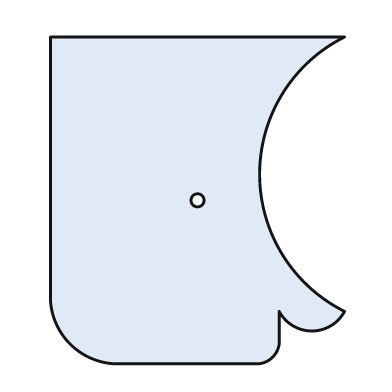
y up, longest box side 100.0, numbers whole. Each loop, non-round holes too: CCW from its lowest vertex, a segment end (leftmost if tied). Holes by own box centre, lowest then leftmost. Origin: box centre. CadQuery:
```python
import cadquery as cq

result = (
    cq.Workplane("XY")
    .moveTo(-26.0, -50.0)
    .lineTo(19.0, -50.0)
    .threePointArc((23.0, -48.0), (25.0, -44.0))
    .lineTo(25.0, -34.0)
    .threePointArc((35.0, -40.0), (45.0, -34.0))
    .threePointArc((19.0, 8.0), (45.0, 50.0))
    .lineTo(-45.0, 50.0)
    .lineTo(-45.0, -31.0)
    .threePointArc((-39.0, -44.0), (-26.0, -50.0))
    .close()
    .moveTo(0.0, 0.0)
    .circle(2.0)
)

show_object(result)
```